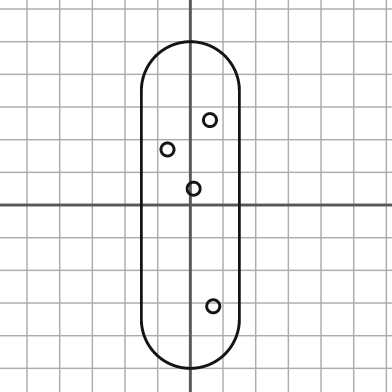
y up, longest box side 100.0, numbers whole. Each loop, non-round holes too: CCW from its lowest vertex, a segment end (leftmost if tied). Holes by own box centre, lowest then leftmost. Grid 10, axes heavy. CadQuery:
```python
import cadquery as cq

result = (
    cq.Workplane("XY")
    .moveTo(-15.0, -35.0)
    .threePointArc((0.0, -50.0), (15.0, -35.0))
    .lineTo(15.0, 35.0)
    .threePointArc((0.0, 50.0), (-15.0, 35.0))
    .close()
    .moveTo(7.0, -31.0)
    .circle(2.0)
    .moveTo(1.0, 5.0)
    .circle(2.0)
    .moveTo(-7.0, 17.0)
    .circle(2.0)
    .moveTo(6.0, 26.0)
    .circle(2.0)
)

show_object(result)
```